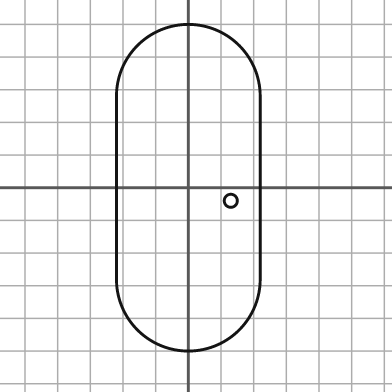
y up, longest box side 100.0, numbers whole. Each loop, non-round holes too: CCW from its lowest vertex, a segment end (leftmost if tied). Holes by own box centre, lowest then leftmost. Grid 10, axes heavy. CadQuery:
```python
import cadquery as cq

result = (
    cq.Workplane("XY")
    .moveTo(-22.0, -28.0)
    .threePointArc((0.0, -50.0), (22.0, -28.0))
    .lineTo(22.0, 28.0)
    .threePointArc((0.0, 50.0), (-22.0, 28.0))
    .close()
    .moveTo(13.0, -4.0)
    .circle(2.0)
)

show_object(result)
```